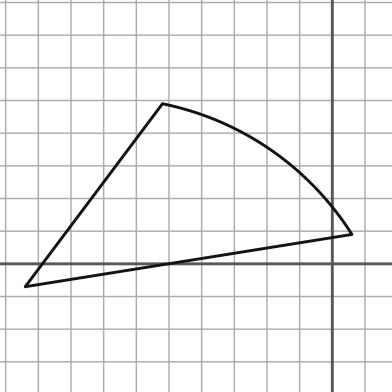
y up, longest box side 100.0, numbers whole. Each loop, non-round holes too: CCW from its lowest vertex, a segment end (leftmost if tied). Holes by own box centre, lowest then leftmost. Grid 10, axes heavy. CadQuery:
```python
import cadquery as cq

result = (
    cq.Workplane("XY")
    .moveTo(-94.0, -7.0)
    .lineTo(6.0, 9.0)
    .threePointArc((-19.0, 35.0), (-52.0, 49.0))
    .close()
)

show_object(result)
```